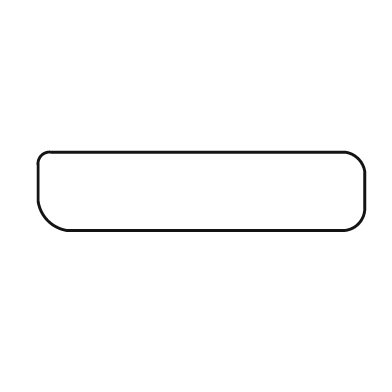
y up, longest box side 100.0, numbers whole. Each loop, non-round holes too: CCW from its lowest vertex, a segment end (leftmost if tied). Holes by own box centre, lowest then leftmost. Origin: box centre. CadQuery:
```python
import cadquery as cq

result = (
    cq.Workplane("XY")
    .moveTo(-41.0, -12.0)
    .lineTo(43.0, -12.0)
    .threePointArc((48.0, -10.0), (50.0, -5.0))
    .lineTo(50.0, 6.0)
    .threePointArc((48.0, 10.0), (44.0, 12.0))
    .lineTo(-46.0, 12.0)
    .threePointArc((-49.0, 11.0), (-50.0, 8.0))
    .lineTo(-50.0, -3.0)
    .threePointArc((-47.0, -9.0), (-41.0, -12.0))
    .close()
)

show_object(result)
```